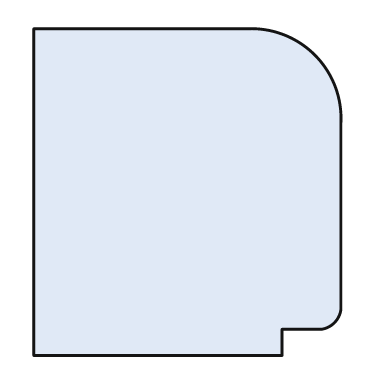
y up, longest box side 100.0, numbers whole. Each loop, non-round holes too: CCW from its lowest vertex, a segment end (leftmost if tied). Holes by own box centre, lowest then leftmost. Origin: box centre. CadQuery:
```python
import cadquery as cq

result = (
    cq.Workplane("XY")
    .moveTo(-47.0, -50.0)
    .lineTo(29.0, -50.0)
    .lineTo(29.0, -42.0)
    .lineTo(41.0, -42.0)
    .threePointArc((45.0, -40.0), (47.0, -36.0))
    .lineTo(47.0, 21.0)
    .threePointArc((39.0, 42.0), (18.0, 50.0))
    .lineTo(-47.0, 50.0)
    .close()
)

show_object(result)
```